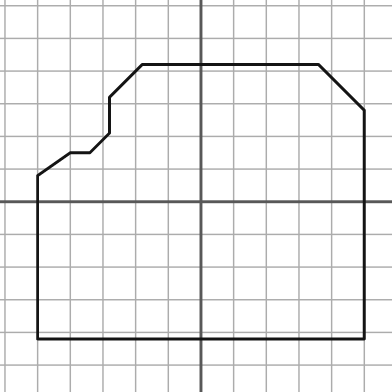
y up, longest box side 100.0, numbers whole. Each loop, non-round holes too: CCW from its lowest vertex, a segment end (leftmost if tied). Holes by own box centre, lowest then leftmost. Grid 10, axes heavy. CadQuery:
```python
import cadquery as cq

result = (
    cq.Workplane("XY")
    .moveTo(-50.0, -42.0)
    .lineTo(50.0, -42.0)
    .lineTo(50.0, 28.0)
    .lineTo(36.0, 42.0)
    .lineTo(-18.0, 42.0)
    .lineTo(-28.0, 32.0)
    .lineTo(-28.0, 21.0)
    .lineTo(-34.0, 15.0)
    .lineTo(-40.0, 15.0)
    .lineTo(-50.0, 8.0)
    .close()
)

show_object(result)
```